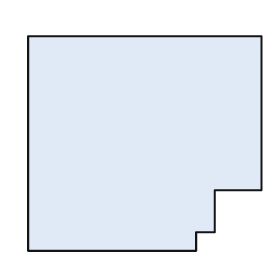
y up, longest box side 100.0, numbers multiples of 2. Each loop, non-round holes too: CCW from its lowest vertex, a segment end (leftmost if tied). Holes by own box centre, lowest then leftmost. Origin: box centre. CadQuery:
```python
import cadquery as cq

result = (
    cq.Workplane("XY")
    .moveTo(-50.0, -46.0)
    .lineTo(22.0, -46.0)
    .lineTo(22.0, -38.0)
    .lineTo(30.0, -38.0)
    .lineTo(30.0, -20.0)
    .lineTo(50.0, -20.0)
    .lineTo(50.0, 46.0)
    .lineTo(-50.0, 46.0)
    .close()
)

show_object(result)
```